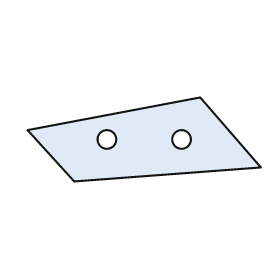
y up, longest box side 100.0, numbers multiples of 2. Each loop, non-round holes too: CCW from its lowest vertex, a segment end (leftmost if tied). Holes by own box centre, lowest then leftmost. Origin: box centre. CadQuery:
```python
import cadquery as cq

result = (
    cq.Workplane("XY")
    .moveTo(-30.0, -18.0)
    .lineTo(50.0, -12.0)
    .lineTo(24.0, 18.0)
    .lineTo(-50.0, 4.0)
    .close()
    .moveTo(-16.0, 0.0)
    .circle(4.0)
    .moveTo(16.0, 0.0)
    .circle(4.0)
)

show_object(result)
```